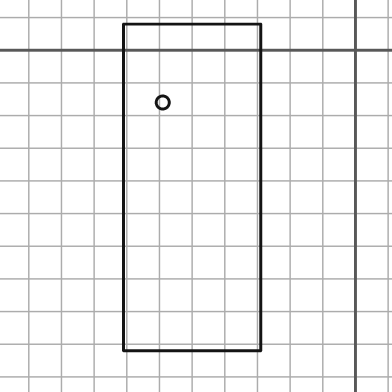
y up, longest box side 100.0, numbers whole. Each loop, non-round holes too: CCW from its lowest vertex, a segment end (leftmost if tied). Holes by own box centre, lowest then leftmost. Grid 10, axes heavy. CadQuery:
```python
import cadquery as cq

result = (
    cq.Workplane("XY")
    .moveTo(-71.0, -92.0)
    .lineTo(-29.0, -92.0)
    .lineTo(-29.0, 8.0)
    .lineTo(-71.0, 8.0)
    .close()
    .moveTo(-59.0, -16.0)
    .circle(2.0)
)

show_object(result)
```